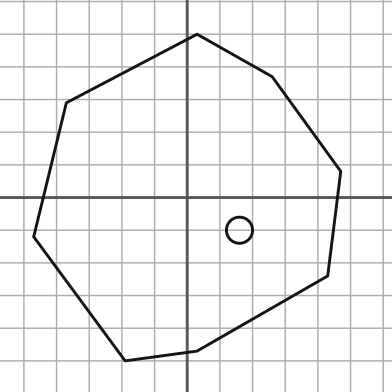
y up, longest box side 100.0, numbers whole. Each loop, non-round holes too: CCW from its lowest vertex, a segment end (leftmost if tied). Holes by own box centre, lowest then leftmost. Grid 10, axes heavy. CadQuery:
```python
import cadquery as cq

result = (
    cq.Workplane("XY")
    .moveTo(-19.0, -50.0)
    .lineTo(3.0, -47.0)
    .lineTo(43.0, -24.0)
    .lineTo(47.0, 8.0)
    .lineTo(26.0, 37.0)
    .lineTo(3.0, 50.0)
    .lineTo(-37.0, 29.0)
    .lineTo(-47.0, -12.0)
    .close()
    .moveTo(16.0, -10.0)
    .circle(4.0)
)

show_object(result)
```